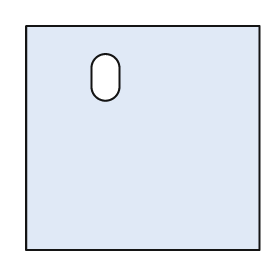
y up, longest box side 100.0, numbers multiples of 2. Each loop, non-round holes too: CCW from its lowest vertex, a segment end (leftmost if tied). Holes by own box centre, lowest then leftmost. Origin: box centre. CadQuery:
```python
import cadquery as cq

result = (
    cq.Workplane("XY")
    .moveTo(-50.0, -48.0)
    .lineTo(50.0, -48.0)
    .lineTo(50.0, 48.0)
    .lineTo(-50.0, 48.0)
    .close()
    .moveTo(-22.0, 22.0)
    .threePointArc((-16.0, 16.0), (-10.0, 22.0))
    .lineTo(-10.0, 30.0)
    .threePointArc((-16.0, 36.0), (-22.0, 30.0))
    .close()
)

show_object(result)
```